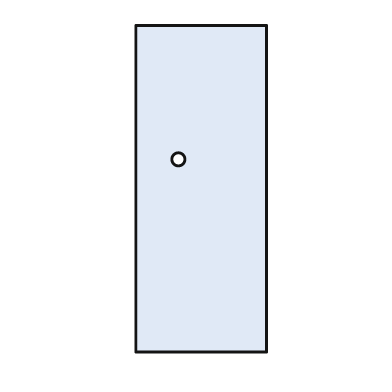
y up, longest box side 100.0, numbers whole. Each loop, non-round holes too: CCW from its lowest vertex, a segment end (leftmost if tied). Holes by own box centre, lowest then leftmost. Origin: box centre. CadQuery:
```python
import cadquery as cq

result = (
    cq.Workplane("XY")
    .moveTo(-20.0, -50.0)
    .lineTo(20.0, -50.0)
    .lineTo(20.0, 50.0)
    .lineTo(-20.0, 50.0)
    .close()
    .moveTo(-7.0, 9.0)
    .circle(2.0)
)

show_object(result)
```